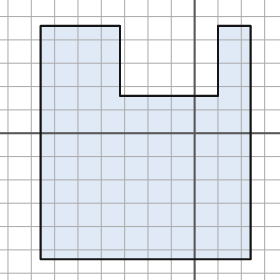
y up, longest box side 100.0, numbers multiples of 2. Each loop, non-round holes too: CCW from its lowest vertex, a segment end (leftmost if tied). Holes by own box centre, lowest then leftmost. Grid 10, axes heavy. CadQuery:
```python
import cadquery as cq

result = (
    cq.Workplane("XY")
    .moveTo(-66.0, -54.0)
    .lineTo(24.0, -54.0)
    .lineTo(24.0, 46.0)
    .lineTo(10.0, 46.0)
    .lineTo(10.0, 16.0)
    .lineTo(-32.0, 16.0)
    .lineTo(-32.0, 46.0)
    .lineTo(-66.0, 46.0)
    .close()
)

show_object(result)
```